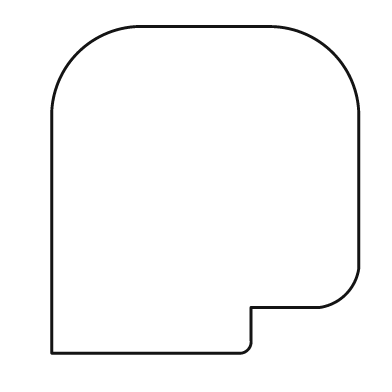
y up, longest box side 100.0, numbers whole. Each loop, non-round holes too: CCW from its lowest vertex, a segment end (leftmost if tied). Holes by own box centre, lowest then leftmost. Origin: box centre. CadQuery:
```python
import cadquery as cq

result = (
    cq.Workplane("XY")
    .moveTo(-47.0, -50.0)
    .lineTo(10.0, -50.0)
    .threePointArc((13.0, -49.0), (14.0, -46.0))
    .lineTo(14.0, -36.0)
    .lineTo(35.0, -36.0)
    .threePointArc((43.0, -32.0), (47.0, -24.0))
    .lineTo(47.0, 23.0)
    .threePointArc((39.0, 42.0), (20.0, 50.0))
    .lineTo(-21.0, 50.0)
    .threePointArc((-39.0, 42.0), (-47.0, 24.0))
    .close()
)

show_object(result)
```